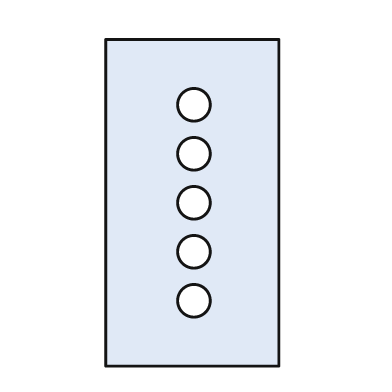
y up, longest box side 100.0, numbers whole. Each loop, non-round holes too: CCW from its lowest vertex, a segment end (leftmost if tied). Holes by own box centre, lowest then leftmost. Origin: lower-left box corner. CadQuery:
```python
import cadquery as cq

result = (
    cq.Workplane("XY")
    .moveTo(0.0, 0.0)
    .lineTo(53.0, 0.0)
    .lineTo(53.0, 100.0)
    .lineTo(0.0, 100.0)
    .close()
    .moveTo(27.0, 20.0)
    .circle(5.0)
    .moveTo(27.0, 35.0)
    .circle(5.0)
    .moveTo(27.0, 50.0)
    .circle(5.0)
    .moveTo(27.0, 65.0)
    .circle(5.0)
    .moveTo(27.0, 80.0)
    .circle(5.0)
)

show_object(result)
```